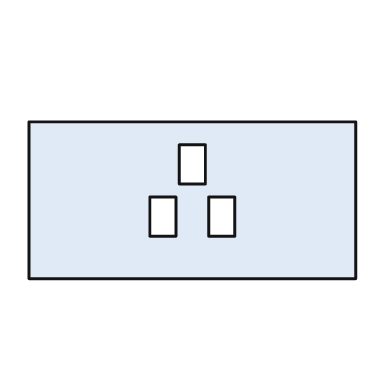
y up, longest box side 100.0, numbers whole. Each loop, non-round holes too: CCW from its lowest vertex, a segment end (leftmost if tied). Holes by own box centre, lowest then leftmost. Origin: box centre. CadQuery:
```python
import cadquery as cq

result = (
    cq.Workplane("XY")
    .moveTo(-50.0, -24.0)
    .lineTo(50.0, -24.0)
    .lineTo(50.0, 24.0)
    .lineTo(-50.0, 24.0)
    .close()
    .moveTo(-13.0, -11.0)
    .lineTo(-5.0, -11.0)
    .lineTo(-5.0, 1.0)
    .lineTo(-13.0, 1.0)
    .close()
    .moveTo(5.0, -11.0)
    .lineTo(13.0, -11.0)
    .lineTo(13.0, 1.0)
    .lineTo(5.0, 1.0)
    .close()
    .moveTo(-4.0, 5.0)
    .lineTo(4.0, 5.0)
    .lineTo(4.0, 17.0)
    .lineTo(-4.0, 17.0)
    .close()
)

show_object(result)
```